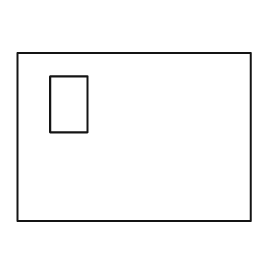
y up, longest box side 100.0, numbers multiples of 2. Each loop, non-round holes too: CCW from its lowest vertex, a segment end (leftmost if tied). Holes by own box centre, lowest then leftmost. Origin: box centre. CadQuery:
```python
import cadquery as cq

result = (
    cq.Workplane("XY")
    .moveTo(-50.0, -36.0)
    .lineTo(50.0, -36.0)
    .lineTo(50.0, 36.0)
    .lineTo(-50.0, 36.0)
    .close()
    .moveTo(-36.0, 2.0)
    .lineTo(-20.0, 2.0)
    .lineTo(-20.0, 26.0)
    .lineTo(-36.0, 26.0)
    .close()
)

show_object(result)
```